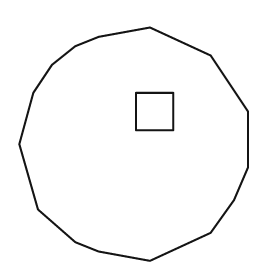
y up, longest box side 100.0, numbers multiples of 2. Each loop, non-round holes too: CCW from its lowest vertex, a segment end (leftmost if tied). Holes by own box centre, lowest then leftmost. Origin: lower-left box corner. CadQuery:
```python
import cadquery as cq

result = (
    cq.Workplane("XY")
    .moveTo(56.0, 0.0)
    .lineTo(82.0, 12.0)
    .lineTo(92.0, 26.0)
    .lineTo(98.0, 40.0)
    .lineTo(98.0, 64.0)
    .lineTo(82.0, 88.0)
    .lineTo(56.0, 100.0)
    .lineTo(34.0, 96.0)
    .lineTo(24.0, 92.0)
    .lineTo(14.0, 84.0)
    .lineTo(6.0, 72.0)
    .lineTo(0.0, 50.0)
    .lineTo(8.0, 22.0)
    .lineTo(24.0, 8.0)
    .lineTo(34.0, 4.0)
    .close()
    .moveTo(50.0, 56.0)
    .lineTo(66.0, 56.0)
    .lineTo(66.0, 72.0)
    .lineTo(50.0, 72.0)
    .close()
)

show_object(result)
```